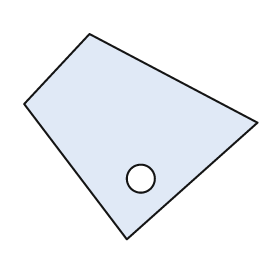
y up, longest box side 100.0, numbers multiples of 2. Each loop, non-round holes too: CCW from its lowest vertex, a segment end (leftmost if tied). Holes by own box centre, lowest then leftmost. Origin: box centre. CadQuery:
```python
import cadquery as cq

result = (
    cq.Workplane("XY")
    .moveTo(-6.0, -44.0)
    .lineTo(50.0, 6.0)
    .lineTo(-22.0, 44.0)
    .lineTo(-50.0, 14.0)
    .close()
    .moveTo(0.0, -18.0)
    .circle(6.0)
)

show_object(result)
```